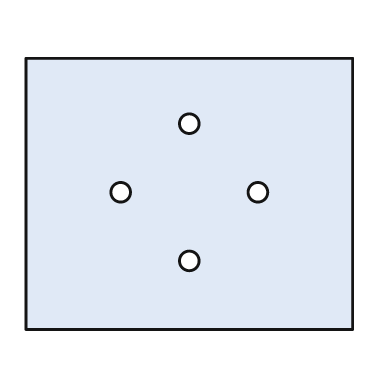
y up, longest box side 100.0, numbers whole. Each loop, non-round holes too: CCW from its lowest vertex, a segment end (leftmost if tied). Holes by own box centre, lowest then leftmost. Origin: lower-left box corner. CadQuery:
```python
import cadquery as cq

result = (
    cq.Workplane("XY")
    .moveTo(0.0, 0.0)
    .lineTo(100.0, 0.0)
    .lineTo(100.0, 83.0)
    .lineTo(0.0, 83.0)
    .close()
    .moveTo(50.0, 21.0)
    .circle(3.0)
    .moveTo(29.0, 42.0)
    .circle(3.0)
    .moveTo(71.0, 42.0)
    .circle(3.0)
    .moveTo(50.0, 63.0)
    .circle(3.0)
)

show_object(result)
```